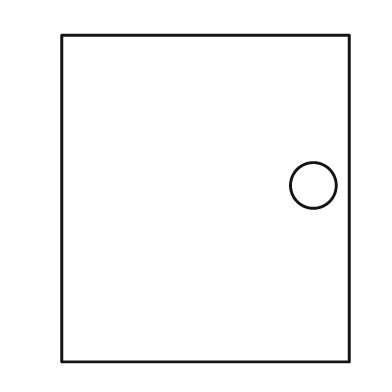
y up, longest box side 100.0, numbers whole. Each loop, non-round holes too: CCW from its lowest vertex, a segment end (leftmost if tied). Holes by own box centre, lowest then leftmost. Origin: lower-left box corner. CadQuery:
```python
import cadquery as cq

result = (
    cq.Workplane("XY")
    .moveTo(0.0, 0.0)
    .lineTo(88.0, 0.0)
    .lineTo(88.0, 100.0)
    .lineTo(0.0, 100.0)
    .close()
    .moveTo(77.0, 54.0)
    .circle(7.0)
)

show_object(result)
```